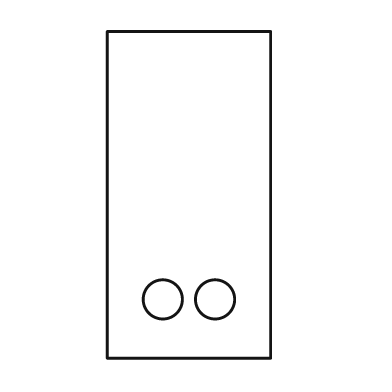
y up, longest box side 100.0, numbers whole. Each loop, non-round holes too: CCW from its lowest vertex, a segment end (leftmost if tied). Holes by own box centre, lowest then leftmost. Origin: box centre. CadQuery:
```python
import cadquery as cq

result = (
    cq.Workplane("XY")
    .moveTo(-25.0, -50.0)
    .lineTo(25.0, -50.0)
    .lineTo(25.0, 50.0)
    .lineTo(-25.0, 50.0)
    .close()
    .moveTo(-8.0, -32.0)
    .circle(6.0)
    .moveTo(8.0, -32.0)
    .circle(6.0)
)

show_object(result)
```